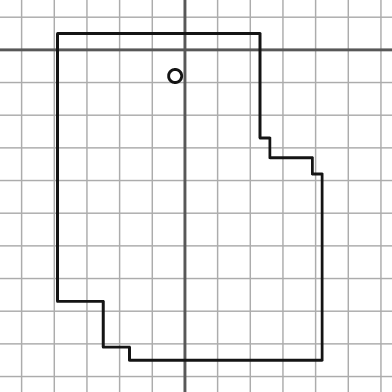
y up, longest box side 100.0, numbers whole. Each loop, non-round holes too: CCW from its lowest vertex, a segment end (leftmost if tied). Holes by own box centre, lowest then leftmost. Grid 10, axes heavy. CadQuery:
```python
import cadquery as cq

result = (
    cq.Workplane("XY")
    .moveTo(-17.0, -95.0)
    .lineTo(42.0, -95.0)
    .lineTo(42.0, -38.0)
    .lineTo(39.0, -38.0)
    .lineTo(39.0, -33.0)
    .lineTo(26.0, -33.0)
    .lineTo(26.0, -27.0)
    .lineTo(23.0, -27.0)
    .lineTo(23.0, 5.0)
    .lineTo(-39.0, 5.0)
    .lineTo(-39.0, -77.0)
    .lineTo(-25.0, -77.0)
    .lineTo(-25.0, -91.0)
    .lineTo(-17.0, -91.0)
    .close()
    .moveTo(-3.0, -8.0)
    .circle(2.0)
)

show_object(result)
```